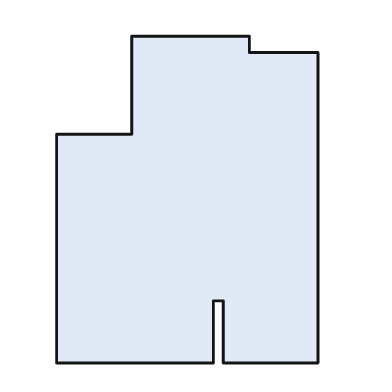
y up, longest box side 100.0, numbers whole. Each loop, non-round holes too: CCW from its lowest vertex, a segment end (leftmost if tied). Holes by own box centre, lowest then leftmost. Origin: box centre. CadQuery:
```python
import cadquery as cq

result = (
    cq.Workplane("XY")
    .moveTo(-40.0, -50.0)
    .lineTo(8.0, -50.0)
    .lineTo(8.0, -31.0)
    .lineTo(11.0, -31.0)
    .lineTo(11.0, -50.0)
    .lineTo(40.0, -50.0)
    .lineTo(40.0, 45.0)
    .lineTo(19.0, 45.0)
    .lineTo(19.0, 50.0)
    .lineTo(-17.0, 50.0)
    .lineTo(-17.0, 20.0)
    .lineTo(-40.0, 20.0)
    .close()
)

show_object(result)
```